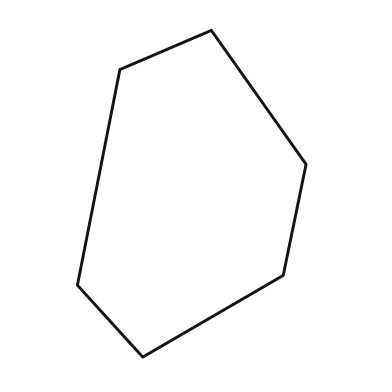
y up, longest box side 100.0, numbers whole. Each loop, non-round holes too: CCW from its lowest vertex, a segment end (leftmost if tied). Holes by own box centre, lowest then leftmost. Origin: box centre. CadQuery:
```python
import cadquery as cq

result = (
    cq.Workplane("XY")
    .moveTo(-15.0, -50.0)
    .lineTo(28.0, -25.0)
    .lineTo(35.0, 9.0)
    .lineTo(6.0, 50.0)
    .lineTo(-22.0, 38.0)
    .lineTo(-35.0, -28.0)
    .close()
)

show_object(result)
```